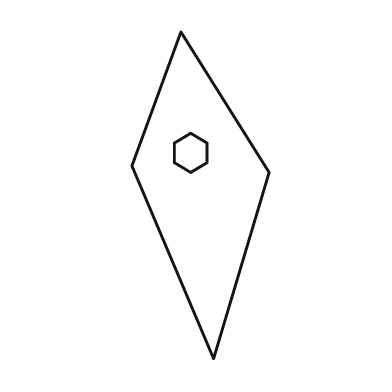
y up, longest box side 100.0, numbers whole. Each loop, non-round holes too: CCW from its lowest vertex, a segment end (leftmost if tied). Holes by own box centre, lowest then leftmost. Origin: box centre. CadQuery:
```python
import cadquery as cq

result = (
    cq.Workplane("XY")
    .moveTo(4.0, -50.0)
    .lineTo(21.0, 7.0)
    .lineTo(-6.0, 50.0)
    .lineTo(-21.0, 9.0)
    .close()
    .moveTo(-3.0, 7.0)
    .lineTo(2.0, 10.0)
    .lineTo(2.0, 16.0)
    .lineTo(-3.0, 19.0)
    .lineTo(-8.0, 16.0)
    .lineTo(-8.0, 10.0)
    .close()
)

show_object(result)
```